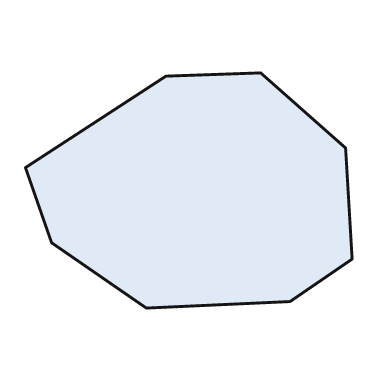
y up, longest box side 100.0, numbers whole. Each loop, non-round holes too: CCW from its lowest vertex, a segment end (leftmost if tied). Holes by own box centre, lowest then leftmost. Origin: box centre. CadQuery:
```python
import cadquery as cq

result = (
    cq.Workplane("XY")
    .moveTo(-13.0, -36.0)
    .lineTo(31.0, -34.0)
    .lineTo(50.0, -21.0)
    .lineTo(48.0, 13.0)
    .lineTo(22.0, 36.0)
    .lineTo(-7.0, 35.0)
    .lineTo(-50.0, 7.0)
    .lineTo(-42.0, -16.0)
    .close()
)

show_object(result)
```